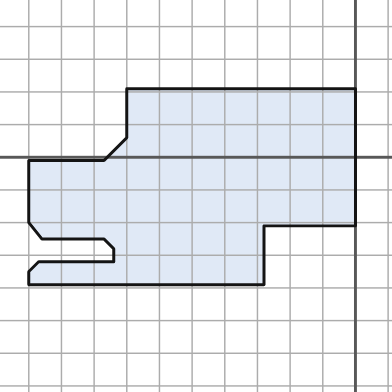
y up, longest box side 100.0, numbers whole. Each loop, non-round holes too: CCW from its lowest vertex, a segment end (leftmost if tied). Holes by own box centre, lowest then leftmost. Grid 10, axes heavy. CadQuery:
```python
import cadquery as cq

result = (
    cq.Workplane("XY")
    .moveTo(-100.0, -39.0)
    .lineTo(-28.0, -39.0)
    .lineTo(-28.0, -21.0)
    .lineTo(0.0, -21.0)
    .lineTo(0.0, 21.0)
    .lineTo(-70.0, 21.0)
    .lineTo(-70.0, 6.0)
    .lineTo(-77.0, -1.0)
    .lineTo(-100.0, -1.0)
    .lineTo(-100.0, -20.0)
    .lineTo(-96.0, -25.0)
    .lineTo(-77.0, -25.0)
    .lineTo(-74.0, -28.0)
    .lineTo(-74.0, -32.0)
    .lineTo(-97.0, -32.0)
    .lineTo(-100.0, -35.0)
    .close()
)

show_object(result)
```